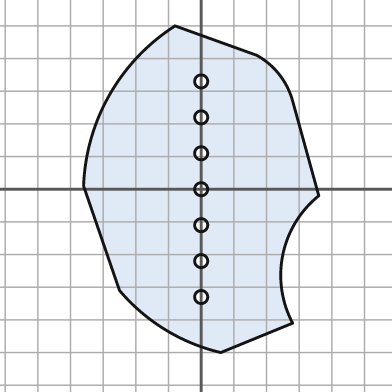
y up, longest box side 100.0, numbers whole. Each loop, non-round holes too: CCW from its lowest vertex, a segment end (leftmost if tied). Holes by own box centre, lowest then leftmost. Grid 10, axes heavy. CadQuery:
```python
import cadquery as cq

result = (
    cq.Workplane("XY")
    .moveTo(6.0, -50.0)
    .lineTo(28.0, -41.0)
    .threePointArc((25.0, -20.0), (36.0, -2.0))
    .lineTo(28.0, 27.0)
    .threePointArc((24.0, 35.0), (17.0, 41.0))
    .lineTo(-8.0, 50.0)
    .threePointArc((-28.0, 29.0), (-36.0, 1.0))
    .lineTo(-25.0, -31.0)
    .threePointArc((-11.0, -43.0), (6.0, -50.0))
    .close()
    .moveTo(0.0, -33.0)
    .circle(2.0)
    .moveTo(0.0, -22.0)
    .circle(2.0)
    .moveTo(0.0, -11.0)
    .circle(2.0)
    .moveTo(0.0, 0.0)
    .circle(2.0)
    .moveTo(0.0, 11.0)
    .circle(2.0)
    .moveTo(0.0, 22.0)
    .circle(2.0)
    .moveTo(0.0, 33.0)
    .circle(2.0)
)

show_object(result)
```